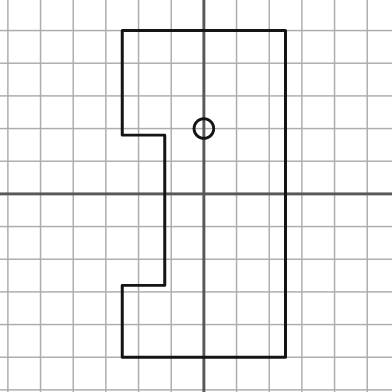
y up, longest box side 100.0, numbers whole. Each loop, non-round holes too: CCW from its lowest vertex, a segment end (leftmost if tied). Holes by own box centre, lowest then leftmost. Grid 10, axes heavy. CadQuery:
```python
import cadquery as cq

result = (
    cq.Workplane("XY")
    .moveTo(-25.0, -50.0)
    .lineTo(25.0, -50.0)
    .lineTo(25.0, 50.0)
    .lineTo(-25.0, 50.0)
    .lineTo(-25.0, 18.0)
    .lineTo(-12.0, 18.0)
    .lineTo(-12.0, -28.0)
    .lineTo(-25.0, -28.0)
    .close()
    .moveTo(0.0, 20.0)
    .circle(3.0)
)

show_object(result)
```